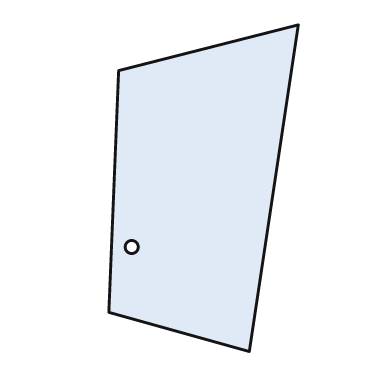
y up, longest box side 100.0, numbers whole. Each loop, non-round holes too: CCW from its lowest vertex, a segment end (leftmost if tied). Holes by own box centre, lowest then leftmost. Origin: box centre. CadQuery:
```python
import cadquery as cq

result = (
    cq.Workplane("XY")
    .moveTo(14.0, -50.0)
    .lineTo(29.0, 50.0)
    .lineTo(-26.0, 36.0)
    .lineTo(-29.0, -38.0)
    .close()
    .moveTo(-22.0, -18.0)
    .circle(2.0)
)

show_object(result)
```